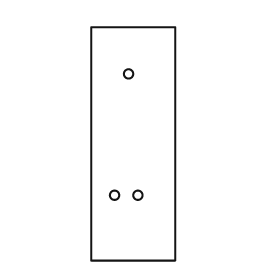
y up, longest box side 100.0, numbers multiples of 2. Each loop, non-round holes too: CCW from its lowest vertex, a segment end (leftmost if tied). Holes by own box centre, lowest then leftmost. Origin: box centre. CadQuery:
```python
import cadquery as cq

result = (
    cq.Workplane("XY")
    .moveTo(-18.0, -50.0)
    .lineTo(18.0, -50.0)
    .lineTo(18.0, 50.0)
    .lineTo(-18.0, 50.0)
    .close()
    .moveTo(-8.0, -22.0)
    .circle(2.0)
    .moveTo(2.0, -22.0)
    .circle(2.0)
    .moveTo(-2.0, 30.0)
    .circle(2.0)
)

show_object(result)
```